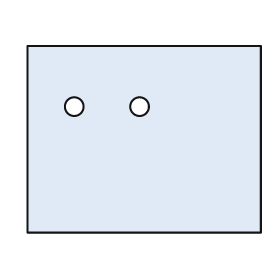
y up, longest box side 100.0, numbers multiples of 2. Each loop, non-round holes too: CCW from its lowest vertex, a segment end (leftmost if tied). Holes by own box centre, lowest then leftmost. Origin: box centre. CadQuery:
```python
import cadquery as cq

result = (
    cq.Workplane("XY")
    .moveTo(-50.0, -40.0)
    .lineTo(50.0, -40.0)
    .lineTo(50.0, 40.0)
    .lineTo(-50.0, 40.0)
    .close()
    .moveTo(-30.0, 14.0)
    .circle(4.0)
    .moveTo(-2.0, 14.0)
    .circle(4.0)
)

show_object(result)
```